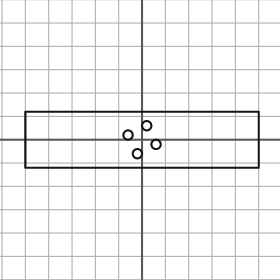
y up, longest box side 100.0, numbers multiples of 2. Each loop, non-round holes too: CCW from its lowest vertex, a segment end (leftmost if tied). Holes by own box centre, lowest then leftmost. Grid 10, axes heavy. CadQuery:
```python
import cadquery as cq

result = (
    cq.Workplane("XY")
    .moveTo(-50.0, -12.0)
    .lineTo(50.0, -12.0)
    .lineTo(50.0, 12.0)
    .lineTo(-50.0, 12.0)
    .close()
    .moveTo(-2.0, -6.0)
    .circle(2.0)
    .moveTo(6.0, -2.0)
    .circle(2.0)
    .moveTo(-6.0, 2.0)
    .circle(2.0)
    .moveTo(2.0, 6.0)
    .circle(2.0)
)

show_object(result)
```